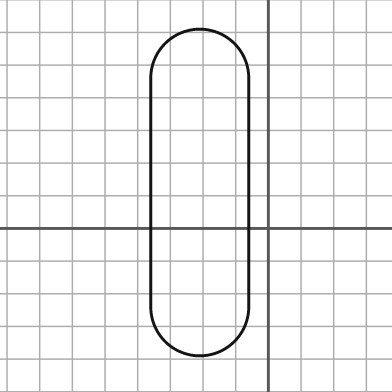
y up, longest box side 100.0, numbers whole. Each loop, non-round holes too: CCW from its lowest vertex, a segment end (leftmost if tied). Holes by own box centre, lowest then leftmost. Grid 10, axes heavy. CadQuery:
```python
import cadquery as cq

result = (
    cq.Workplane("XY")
    .moveTo(-36.0, -24.0)
    .threePointArc((-21.0, -39.0), (-6.0, -24.0))
    .lineTo(-6.0, 46.0)
    .threePointArc((-21.0, 61.0), (-36.0, 46.0))
    .close()
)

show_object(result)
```